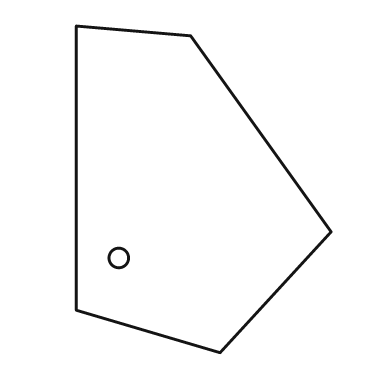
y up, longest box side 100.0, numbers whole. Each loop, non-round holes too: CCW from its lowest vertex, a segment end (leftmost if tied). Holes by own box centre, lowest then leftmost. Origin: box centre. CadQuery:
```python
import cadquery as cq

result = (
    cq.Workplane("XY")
    .moveTo(5.0, -50.0)
    .lineTo(39.0, -13.0)
    .lineTo(-4.0, 47.0)
    .lineTo(-39.0, 50.0)
    .lineTo(-39.0, -37.0)
    .close()
    .moveTo(-26.0, -21.0)
    .circle(3.0)
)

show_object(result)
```